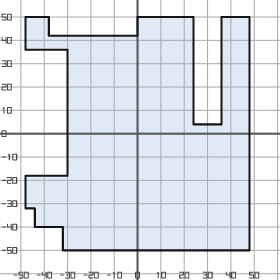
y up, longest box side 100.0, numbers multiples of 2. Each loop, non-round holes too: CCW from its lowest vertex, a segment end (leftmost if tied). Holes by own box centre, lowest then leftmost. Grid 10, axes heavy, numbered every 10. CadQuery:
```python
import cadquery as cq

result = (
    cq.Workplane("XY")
    .moveTo(-32.0, -50.0)
    .lineTo(48.0, -50.0)
    .lineTo(48.0, 50.0)
    .lineTo(36.0, 50.0)
    .lineTo(36.0, 4.0)
    .lineTo(24.0, 4.0)
    .lineTo(24.0, 50.0)
    .lineTo(0.0, 50.0)
    .lineTo(0.0, 42.0)
    .lineTo(-38.0, 42.0)
    .lineTo(-38.0, 50.0)
    .lineTo(-48.0, 50.0)
    .lineTo(-48.0, 36.0)
    .lineTo(-30.0, 36.0)
    .lineTo(-30.0, -18.0)
    .lineTo(-48.0, -18.0)
    .lineTo(-48.0, -32.0)
    .lineTo(-44.0, -32.0)
    .lineTo(-44.0, -40.0)
    .lineTo(-32.0, -40.0)
    .close()
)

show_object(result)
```